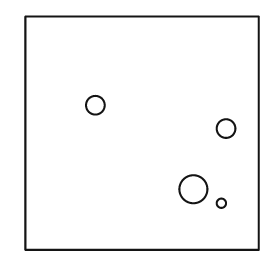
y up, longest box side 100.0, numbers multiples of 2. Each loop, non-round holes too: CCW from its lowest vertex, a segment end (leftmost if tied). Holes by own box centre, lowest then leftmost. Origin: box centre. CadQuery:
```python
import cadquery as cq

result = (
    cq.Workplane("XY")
    .moveTo(-50.0, -50.0)
    .lineTo(50.0, -50.0)
    .lineTo(50.0, 50.0)
    .lineTo(-50.0, 50.0)
    .close()
    .moveTo(34.0, -30.0)
    .circle(2.0)
    .moveTo(22.0, -24.0)
    .circle(6.0)
    .moveTo(36.0, 2.0)
    .circle(4.0)
    .moveTo(-20.0, 12.0)
    .circle(4.0)
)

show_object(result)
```